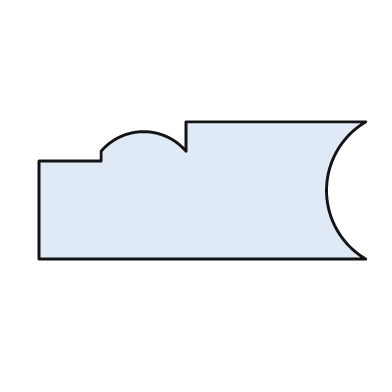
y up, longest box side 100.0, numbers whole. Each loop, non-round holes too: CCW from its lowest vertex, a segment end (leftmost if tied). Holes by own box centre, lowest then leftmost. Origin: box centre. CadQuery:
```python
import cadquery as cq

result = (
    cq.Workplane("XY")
    .moveTo(-50.0, -21.0)
    .lineTo(50.0, -21.0)
    .threePointArc((38.0, 0.0), (50.0, 21.0))
    .lineTo(-5.0, 21.0)
    .lineTo(-5.0, 12.0)
    .threePointArc((-18.0, 18.0), (-31.0, 12.0))
    .lineTo(-31.0, 9.0)
    .lineTo(-50.0, 9.0)
    .close()
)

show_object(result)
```